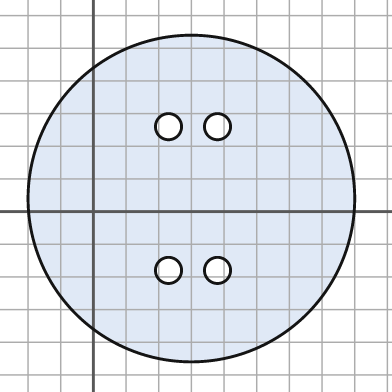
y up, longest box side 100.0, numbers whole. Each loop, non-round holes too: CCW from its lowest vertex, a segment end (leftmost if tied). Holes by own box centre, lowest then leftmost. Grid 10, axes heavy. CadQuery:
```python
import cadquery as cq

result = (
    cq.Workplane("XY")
    .moveTo(30.0, 4.0)
    .circle(50.0)
    .moveTo(23.0, -18.0)
    .circle(4.0)
    .moveTo(38.0, -18.0)
    .circle(4.0)
    .moveTo(23.0, 26.0)
    .circle(4.0)
    .moveTo(38.0, 26.0)
    .circle(4.0)
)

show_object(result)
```